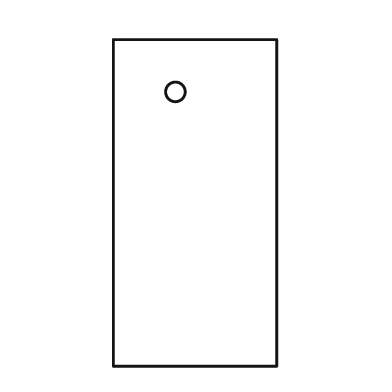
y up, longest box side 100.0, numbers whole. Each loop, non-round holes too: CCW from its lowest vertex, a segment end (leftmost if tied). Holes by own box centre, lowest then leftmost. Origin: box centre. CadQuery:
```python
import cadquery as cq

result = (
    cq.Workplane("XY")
    .moveTo(-25.0, -50.0)
    .lineTo(25.0, -50.0)
    .lineTo(25.0, 50.0)
    .lineTo(-25.0, 50.0)
    .close()
    .moveTo(-6.0, 34.0)
    .circle(3.0)
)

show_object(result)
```